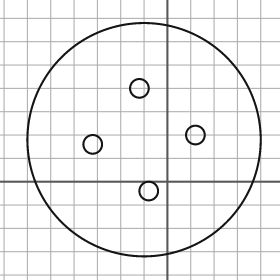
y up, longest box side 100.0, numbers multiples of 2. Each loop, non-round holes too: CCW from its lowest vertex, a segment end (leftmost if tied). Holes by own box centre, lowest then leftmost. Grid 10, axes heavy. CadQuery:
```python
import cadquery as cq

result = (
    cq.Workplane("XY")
    .moveTo(-10.0, 18.0)
    .circle(50.0)
    .moveTo(-8.0, -4.0)
    .circle(4.0)
    .moveTo(-32.0, 16.0)
    .circle(4.0)
    .moveTo(12.0, 20.0)
    .circle(4.0)
    .moveTo(-12.0, 40.0)
    .circle(4.0)
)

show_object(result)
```